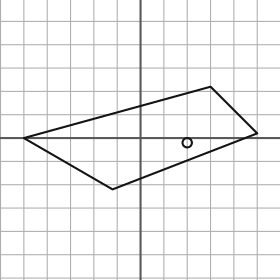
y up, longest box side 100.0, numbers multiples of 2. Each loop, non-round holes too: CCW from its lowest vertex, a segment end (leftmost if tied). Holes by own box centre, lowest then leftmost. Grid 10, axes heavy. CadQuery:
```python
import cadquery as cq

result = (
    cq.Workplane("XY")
    .moveTo(-12.0, -22.0)
    .lineTo(50.0, 2.0)
    .lineTo(30.0, 22.0)
    .lineTo(-50.0, 0.0)
    .close()
    .moveTo(20.0, -2.0)
    .circle(2.0)
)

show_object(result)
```